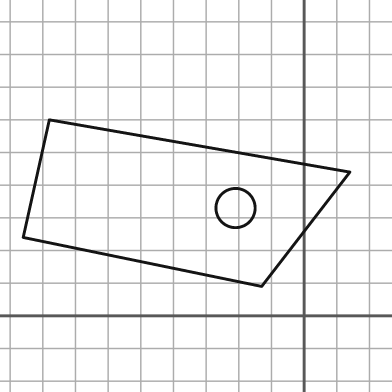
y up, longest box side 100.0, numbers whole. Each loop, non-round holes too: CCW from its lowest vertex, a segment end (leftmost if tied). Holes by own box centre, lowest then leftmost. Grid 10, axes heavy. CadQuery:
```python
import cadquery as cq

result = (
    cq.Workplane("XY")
    .moveTo(-13.0, 9.0)
    .lineTo(14.0, 44.0)
    .lineTo(-78.0, 60.0)
    .lineTo(-86.0, 24.0)
    .close()
    .moveTo(-21.0, 33.0)
    .circle(6.0)
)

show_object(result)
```